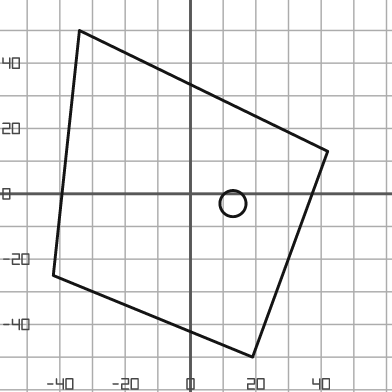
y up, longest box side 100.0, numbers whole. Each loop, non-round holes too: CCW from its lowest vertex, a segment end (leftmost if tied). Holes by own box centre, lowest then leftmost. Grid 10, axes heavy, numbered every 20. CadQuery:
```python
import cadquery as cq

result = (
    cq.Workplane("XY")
    .moveTo(19.0, -50.0)
    .lineTo(42.0, 13.0)
    .lineTo(-34.0, 50.0)
    .lineTo(-42.0, -25.0)
    .close()
    .moveTo(13.0, -3.0)
    .circle(4.0)
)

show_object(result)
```